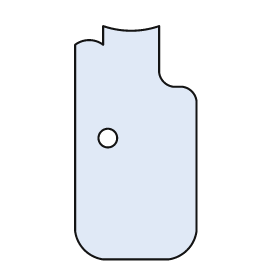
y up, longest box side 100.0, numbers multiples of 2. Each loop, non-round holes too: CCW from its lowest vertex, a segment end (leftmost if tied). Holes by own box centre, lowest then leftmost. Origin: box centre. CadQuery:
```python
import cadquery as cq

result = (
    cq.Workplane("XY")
    .moveTo(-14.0, -50.0)
    .lineTo(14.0, -50.0)
    .threePointArc((22.0, -46.0), (26.0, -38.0))
    .lineTo(26.0, 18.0)
    .threePointArc((24.0, 22.0), (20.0, 24.0))
    .lineTo(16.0, 24.0)
    .threePointArc((12.0, 26.0), (10.0, 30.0))
    .lineTo(10.0, 50.0)
    .threePointArc((-2.0, 48.0), (-14.0, 50.0))
    .lineTo(-14.0, 42.0)
    .threePointArc((-20.0, 44.0), (-26.0, 42.0))
    .lineTo(-26.0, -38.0)
    .threePointArc((-22.0, -46.0), (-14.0, -50.0))
    .close()
    .moveTo(-12.0, 2.0)
    .circle(4.0)
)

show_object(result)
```